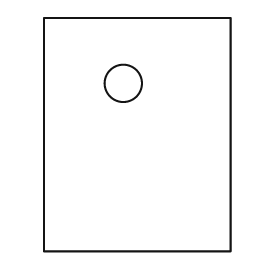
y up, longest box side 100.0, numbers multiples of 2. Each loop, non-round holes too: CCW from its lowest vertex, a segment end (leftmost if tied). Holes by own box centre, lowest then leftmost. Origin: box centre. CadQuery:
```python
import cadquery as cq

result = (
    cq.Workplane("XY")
    .moveTo(-40.0, -50.0)
    .lineTo(40.0, -50.0)
    .lineTo(40.0, 50.0)
    .lineTo(-40.0, 50.0)
    .close()
    .moveTo(-6.0, 22.0)
    .circle(8.0)
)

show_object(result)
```